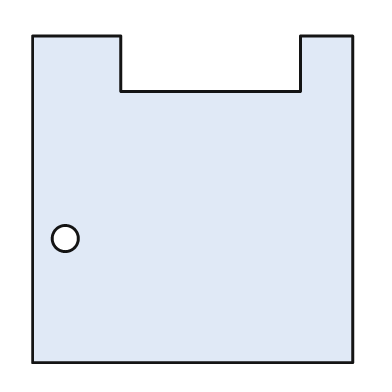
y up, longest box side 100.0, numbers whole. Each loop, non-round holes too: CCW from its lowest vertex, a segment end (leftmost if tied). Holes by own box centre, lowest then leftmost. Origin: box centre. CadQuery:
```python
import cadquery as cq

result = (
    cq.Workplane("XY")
    .moveTo(-49.0, -50.0)
    .lineTo(49.0, -50.0)
    .lineTo(49.0, 50.0)
    .lineTo(33.0, 50.0)
    .lineTo(33.0, 33.0)
    .lineTo(-22.0, 33.0)
    .lineTo(-22.0, 50.0)
    .lineTo(-49.0, 50.0)
    .close()
    .moveTo(-39.0, -12.0)
    .circle(4.0)
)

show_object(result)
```